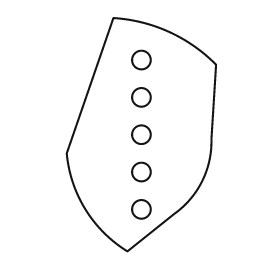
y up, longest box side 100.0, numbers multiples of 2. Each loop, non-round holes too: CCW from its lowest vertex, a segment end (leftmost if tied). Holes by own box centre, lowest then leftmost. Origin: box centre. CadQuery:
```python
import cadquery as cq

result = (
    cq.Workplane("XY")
    .moveTo(-6.0, -50.0)
    .lineTo(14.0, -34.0)
    .threePointArc((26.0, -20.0), (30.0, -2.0))
    .lineTo(32.0, 30.0)
    .threePointArc((12.0, 44.0), (-12.0, 50.0))
    .lineTo(-32.0, -8.0)
    .threePointArc((-24.0, -32.0), (-6.0, -50.0))
    .close()
    .moveTo(0.0, -32.0)
    .circle(4.0)
    .moveTo(0.0, -16.0)
    .circle(4.0)
    .moveTo(0.0, 0.0)
    .circle(4.0)
    .moveTo(0.0, 16.0)
    .circle(4.0)
    .moveTo(0.0, 32.0)
    .circle(4.0)
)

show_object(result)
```